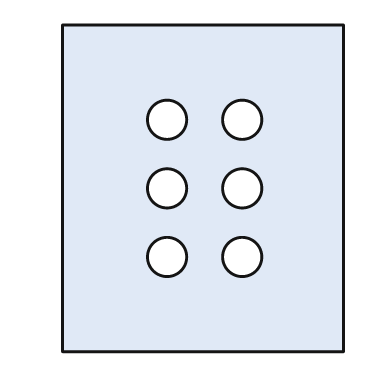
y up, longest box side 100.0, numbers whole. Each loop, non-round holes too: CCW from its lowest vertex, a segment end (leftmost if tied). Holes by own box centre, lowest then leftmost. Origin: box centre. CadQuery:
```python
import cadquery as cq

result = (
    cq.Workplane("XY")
    .moveTo(-43.0, -50.0)
    .lineTo(43.0, -50.0)
    .lineTo(43.0, 50.0)
    .lineTo(-43.0, 50.0)
    .close()
    .moveTo(-11.0, -21.0)
    .circle(6.0)
    .moveTo(12.0, -21.0)
    .circle(6.0)
    .moveTo(-11.0, 0.0)
    .circle(6.0)
    .moveTo(12.0, 0.0)
    .circle(6.0)
    .moveTo(-11.0, 21.0)
    .circle(6.0)
    .moveTo(12.0, 21.0)
    .circle(6.0)
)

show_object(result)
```